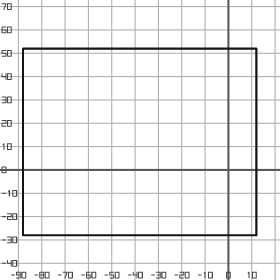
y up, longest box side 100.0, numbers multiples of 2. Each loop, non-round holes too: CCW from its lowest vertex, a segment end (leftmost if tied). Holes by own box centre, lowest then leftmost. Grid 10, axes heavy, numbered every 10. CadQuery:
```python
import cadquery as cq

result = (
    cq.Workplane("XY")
    .moveTo(-88.0, -28.0)
    .lineTo(12.0, -28.0)
    .lineTo(12.0, 52.0)
    .lineTo(-88.0, 52.0)
    .close()
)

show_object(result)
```